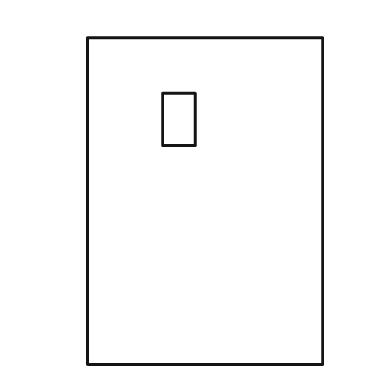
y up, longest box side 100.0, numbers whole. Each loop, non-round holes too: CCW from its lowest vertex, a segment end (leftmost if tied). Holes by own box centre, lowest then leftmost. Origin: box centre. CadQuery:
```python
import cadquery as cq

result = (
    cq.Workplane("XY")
    .moveTo(-36.0, -50.0)
    .lineTo(36.0, -50.0)
    .lineTo(36.0, 50.0)
    .lineTo(-36.0, 50.0)
    .close()
    .moveTo(-13.0, 17.0)
    .lineTo(-3.0, 17.0)
    .lineTo(-3.0, 33.0)
    .lineTo(-13.0, 33.0)
    .close()
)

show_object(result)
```